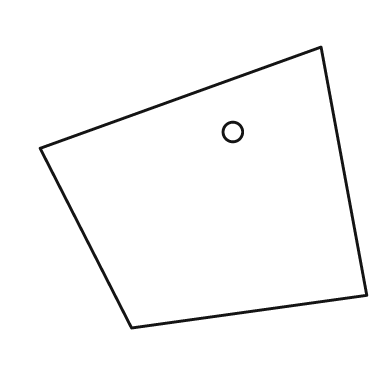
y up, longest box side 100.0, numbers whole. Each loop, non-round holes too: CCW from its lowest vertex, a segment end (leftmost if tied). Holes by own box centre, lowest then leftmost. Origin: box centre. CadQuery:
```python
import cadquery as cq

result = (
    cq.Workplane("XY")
    .moveTo(-22.0, -43.0)
    .lineTo(50.0, -33.0)
    .lineTo(36.0, 43.0)
    .lineTo(-50.0, 12.0)
    .close()
    .moveTo(9.0, 17.0)
    .circle(3.0)
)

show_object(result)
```